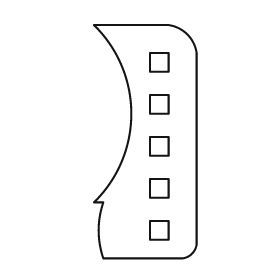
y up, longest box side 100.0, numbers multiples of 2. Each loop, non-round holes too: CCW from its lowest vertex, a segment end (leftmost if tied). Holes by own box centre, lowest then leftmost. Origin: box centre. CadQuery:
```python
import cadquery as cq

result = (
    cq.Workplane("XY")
    .moveTo(-18.0, -50.0)
    .lineTo(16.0, -50.0)
    .threePointArc((20.0, -48.0), (22.0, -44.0))
    .lineTo(22.0, 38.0)
    .threePointArc((18.0, 46.0), (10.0, 50.0))
    .lineTo(-22.0, 50.0)
    .threePointArc((-6.0, 12.0), (-22.0, -26.0))
    .lineTo(-18.0, -26.0)
    .threePointArc((-20.0, -38.0), (-18.0, -50.0))
    .close()
    .moveTo(2.0, -42.0)
    .lineTo(10.0, -42.0)
    .lineTo(10.0, -34.0)
    .lineTo(2.0, -34.0)
    .close()
    .moveTo(2.0, -24.0)
    .lineTo(10.0, -24.0)
    .lineTo(10.0, -16.0)
    .lineTo(2.0, -16.0)
    .close()
    .moveTo(2.0, -6.0)
    .lineTo(10.0, -6.0)
    .lineTo(10.0, 2.0)
    .lineTo(2.0, 2.0)
    .close()
    .moveTo(2.0, 12.0)
    .lineTo(10.0, 12.0)
    .lineTo(10.0, 20.0)
    .lineTo(2.0, 20.0)
    .close()
    .moveTo(2.0, 30.0)
    .lineTo(10.0, 30.0)
    .lineTo(10.0, 38.0)
    .lineTo(2.0, 38.0)
    .close()
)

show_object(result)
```